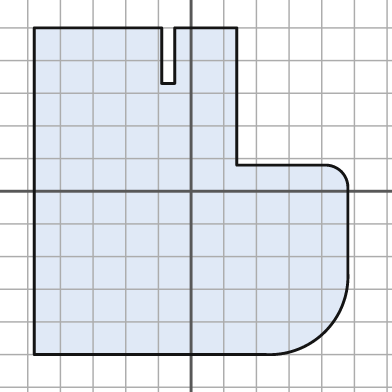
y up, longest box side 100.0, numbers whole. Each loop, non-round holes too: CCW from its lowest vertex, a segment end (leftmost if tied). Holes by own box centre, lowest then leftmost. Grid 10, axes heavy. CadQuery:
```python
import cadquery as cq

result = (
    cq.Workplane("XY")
    .moveTo(-48.0, -50.0)
    .lineTo(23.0, -50.0)
    .threePointArc((41.0, -43.0), (48.0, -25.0))
    .lineTo(48.0, 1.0)
    .threePointArc((46.0, 6.0), (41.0, 8.0))
    .lineTo(14.0, 8.0)
    .lineTo(14.0, 50.0)
    .lineTo(-5.0, 50.0)
    .lineTo(-5.0, 33.0)
    .lineTo(-9.0, 33.0)
    .lineTo(-9.0, 50.0)
    .lineTo(-48.0, 50.0)
    .close()
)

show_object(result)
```